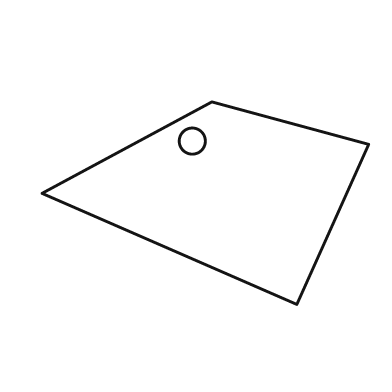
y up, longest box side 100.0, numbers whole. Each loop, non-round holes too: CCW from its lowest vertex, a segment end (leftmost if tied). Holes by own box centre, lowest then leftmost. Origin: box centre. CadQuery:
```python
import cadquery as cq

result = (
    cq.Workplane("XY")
    .moveTo(28.0, -31.0)
    .lineTo(50.0, 18.0)
    .lineTo(2.0, 31.0)
    .lineTo(-50.0, 3.0)
    .close()
    .moveTo(-4.0, 19.0)
    .circle(4.0)
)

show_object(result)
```